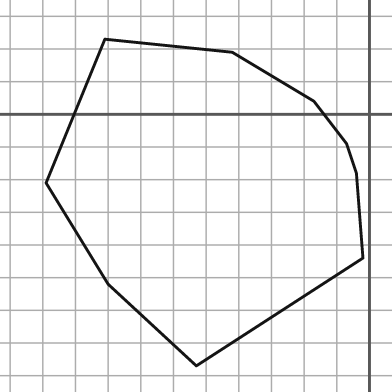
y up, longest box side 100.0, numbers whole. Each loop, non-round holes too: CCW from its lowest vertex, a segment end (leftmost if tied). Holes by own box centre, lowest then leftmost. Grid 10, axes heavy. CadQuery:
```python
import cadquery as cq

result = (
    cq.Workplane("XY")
    .moveTo(-53.0, -77.0)
    .lineTo(-2.0, -44.0)
    .lineTo(-4.0, -18.0)
    .lineTo(-7.0, -9.0)
    .lineTo(-17.0, 4.0)
    .lineTo(-42.0, 19.0)
    .lineTo(-81.0, 23.0)
    .lineTo(-99.0, -21.0)
    .lineTo(-80.0, -52.0)
    .close()
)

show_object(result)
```